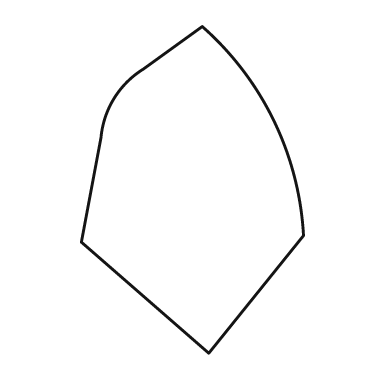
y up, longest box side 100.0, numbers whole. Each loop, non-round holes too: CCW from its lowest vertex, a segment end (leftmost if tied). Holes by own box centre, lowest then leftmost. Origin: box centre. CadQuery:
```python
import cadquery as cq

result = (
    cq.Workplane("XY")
    .moveTo(5.0, -50.0)
    .lineTo(34.0, -14.0)
    .threePointArc((25.0, 21.0), (3.0, 50.0))
    .lineTo(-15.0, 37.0)
    .threePointArc((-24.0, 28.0), (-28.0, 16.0))
    .lineTo(-34.0, -16.0)
    .close()
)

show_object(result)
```